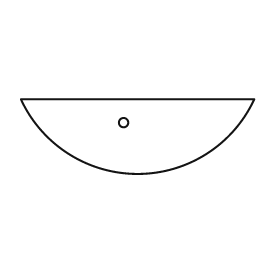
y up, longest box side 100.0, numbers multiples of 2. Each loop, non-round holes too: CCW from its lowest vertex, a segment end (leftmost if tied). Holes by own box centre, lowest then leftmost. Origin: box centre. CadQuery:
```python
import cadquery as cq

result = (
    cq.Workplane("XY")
    .moveTo(-50.0, 16.0)
    .threePointArc((0.0, -16.0), (50.0, 16.0))
    .close()
    .moveTo(-6.0, 6.0)
    .circle(2.0)
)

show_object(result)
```